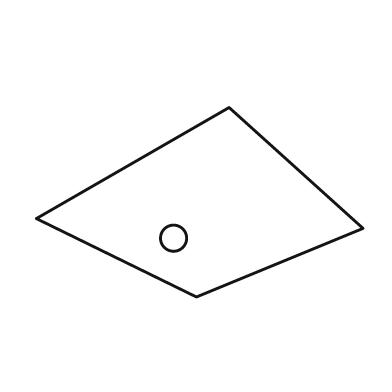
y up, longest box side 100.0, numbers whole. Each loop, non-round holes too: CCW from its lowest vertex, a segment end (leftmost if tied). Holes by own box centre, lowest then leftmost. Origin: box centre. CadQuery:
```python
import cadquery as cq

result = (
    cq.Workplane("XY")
    .moveTo(-1.0, -29.0)
    .lineTo(50.0, -8.0)
    .lineTo(9.0, 29.0)
    .lineTo(-50.0, -5.0)
    .close()
    .moveTo(-8.0, -11.0)
    .circle(4.0)
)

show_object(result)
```